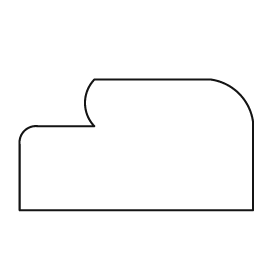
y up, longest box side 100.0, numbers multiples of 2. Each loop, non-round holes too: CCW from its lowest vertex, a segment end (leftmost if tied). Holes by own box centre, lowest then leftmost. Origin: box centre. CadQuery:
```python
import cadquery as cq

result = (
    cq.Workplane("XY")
    .moveTo(-50.0, -28.0)
    .lineTo(50.0, -28.0)
    .lineTo(50.0, 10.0)
    .threePointArc((44.0, 22.0), (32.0, 28.0))
    .lineTo(-18.0, 28.0)
    .threePointArc((-22.0, 18.0), (-18.0, 8.0))
    .lineTo(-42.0, 8.0)
    .threePointArc((-48.0, 6.0), (-50.0, 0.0))
    .close()
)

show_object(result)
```